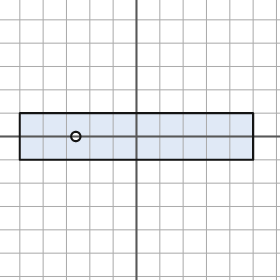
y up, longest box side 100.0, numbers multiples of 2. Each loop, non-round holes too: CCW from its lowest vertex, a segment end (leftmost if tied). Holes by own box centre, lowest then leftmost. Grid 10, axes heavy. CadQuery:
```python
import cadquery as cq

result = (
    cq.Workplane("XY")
    .moveTo(-50.0, -10.0)
    .lineTo(50.0, -10.0)
    .lineTo(50.0, 10.0)
    .lineTo(-50.0, 10.0)
    .close()
    .moveTo(-26.0, 0.0)
    .circle(2.0)
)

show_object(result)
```